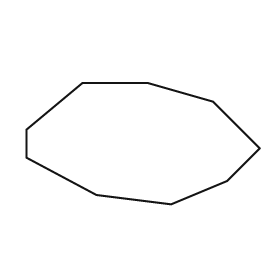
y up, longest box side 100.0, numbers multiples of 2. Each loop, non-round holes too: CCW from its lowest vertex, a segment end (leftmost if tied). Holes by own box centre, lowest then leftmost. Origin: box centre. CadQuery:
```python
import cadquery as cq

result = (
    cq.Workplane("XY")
    .moveTo(12.0, -26.0)
    .lineTo(36.0, -16.0)
    .lineTo(50.0, -2.0)
    .lineTo(30.0, 18.0)
    .lineTo(2.0, 26.0)
    .lineTo(-26.0, 26.0)
    .lineTo(-50.0, 6.0)
    .lineTo(-50.0, -6.0)
    .lineTo(-20.0, -22.0)
    .close()
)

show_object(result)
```